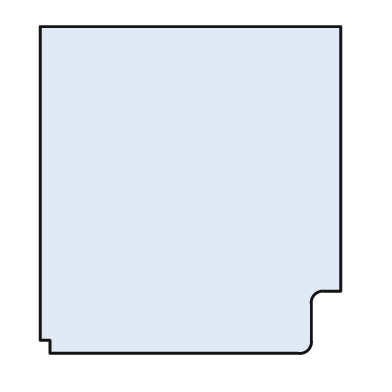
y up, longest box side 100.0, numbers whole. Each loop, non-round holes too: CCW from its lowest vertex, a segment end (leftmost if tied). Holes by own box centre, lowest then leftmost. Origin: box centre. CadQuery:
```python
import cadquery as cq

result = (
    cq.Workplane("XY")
    .moveTo(-43.0, -50.0)
    .lineTo(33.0, -50.0)
    .threePointArc((36.0, -49.0), (37.0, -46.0))
    .lineTo(37.0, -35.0)
    .threePointArc((38.0, -32.0), (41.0, -31.0))
    .lineTo(46.0, -31.0)
    .lineTo(46.0, 50.0)
    .lineTo(-46.0, 50.0)
    .lineTo(-46.0, -46.0)
    .lineTo(-43.0, -46.0)
    .close()
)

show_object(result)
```